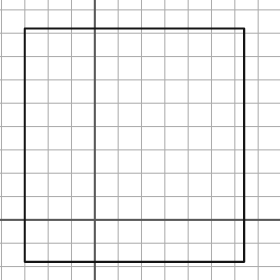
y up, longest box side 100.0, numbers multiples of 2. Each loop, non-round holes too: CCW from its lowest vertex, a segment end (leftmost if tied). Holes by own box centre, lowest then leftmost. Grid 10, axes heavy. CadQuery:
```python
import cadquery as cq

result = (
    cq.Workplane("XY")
    .moveTo(-30.0, -18.0)
    .lineTo(64.0, -18.0)
    .lineTo(64.0, 82.0)
    .lineTo(-30.0, 82.0)
    .close()
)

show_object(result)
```